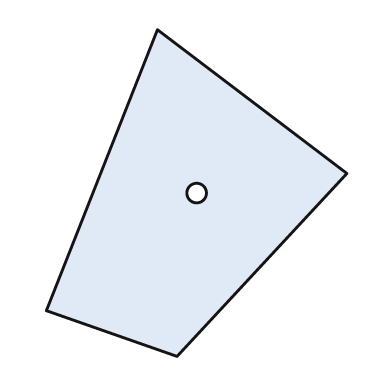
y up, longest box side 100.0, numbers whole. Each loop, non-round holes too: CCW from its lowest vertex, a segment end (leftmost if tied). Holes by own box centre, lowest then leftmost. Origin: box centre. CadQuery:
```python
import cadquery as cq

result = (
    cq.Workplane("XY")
    .moveTo(-6.0, -50.0)
    .lineTo(46.0, 6.0)
    .lineTo(-12.0, 50.0)
    .lineTo(-46.0, -36.0)
    .close()
    .moveTo(0.0, 0.0)
    .circle(3.0)
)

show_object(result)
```